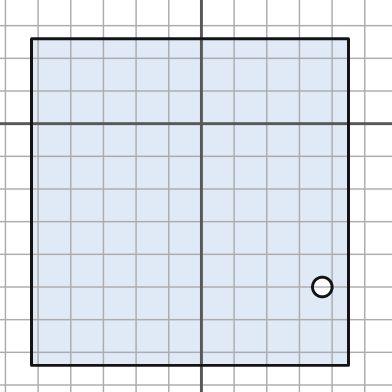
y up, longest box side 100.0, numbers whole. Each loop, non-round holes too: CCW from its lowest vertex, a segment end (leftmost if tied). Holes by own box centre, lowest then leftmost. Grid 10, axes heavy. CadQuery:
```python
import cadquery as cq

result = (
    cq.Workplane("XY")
    .moveTo(-52.0, -74.0)
    .lineTo(45.0, -74.0)
    .lineTo(45.0, 26.0)
    .lineTo(-52.0, 26.0)
    .close()
    .moveTo(37.0, -50.0)
    .circle(3.0)
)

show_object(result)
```